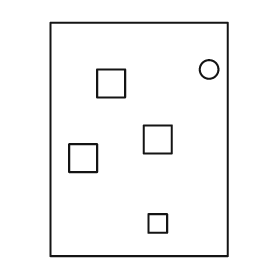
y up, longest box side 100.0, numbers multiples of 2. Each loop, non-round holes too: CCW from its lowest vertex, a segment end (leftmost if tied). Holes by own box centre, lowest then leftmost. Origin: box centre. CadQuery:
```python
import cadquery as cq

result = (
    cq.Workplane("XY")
    .moveTo(-38.0, -50.0)
    .lineTo(38.0, -50.0)
    .lineTo(38.0, 50.0)
    .lineTo(-38.0, 50.0)
    .close()
    .moveTo(4.0, -40.0)
    .lineTo(12.0, -40.0)
    .lineTo(12.0, -32.0)
    .lineTo(4.0, -32.0)
    .close()
    .moveTo(-30.0, -14.0)
    .lineTo(-18.0, -14.0)
    .lineTo(-18.0, -2.0)
    .lineTo(-30.0, -2.0)
    .close()
    .moveTo(2.0, -6.0)
    .lineTo(14.0, -6.0)
    .lineTo(14.0, 6.0)
    .lineTo(2.0, 6.0)
    .close()
    .moveTo(-18.0, 18.0)
    .lineTo(-6.0, 18.0)
    .lineTo(-6.0, 30.0)
    .lineTo(-18.0, 30.0)
    .close()
    .moveTo(30.0, 30.0)
    .circle(4.0)
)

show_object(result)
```